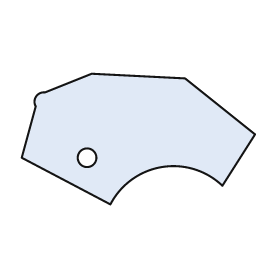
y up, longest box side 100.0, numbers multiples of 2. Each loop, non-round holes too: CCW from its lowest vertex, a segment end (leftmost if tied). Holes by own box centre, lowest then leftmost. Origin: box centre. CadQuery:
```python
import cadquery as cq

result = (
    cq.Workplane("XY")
    .moveTo(-12.0, -28.0)
    .threePointArc((10.0, -12.0), (36.0, -20.0))
    .lineTo(50.0, 2.0)
    .lineTo(20.0, 26.0)
    .lineTo(-20.0, 28.0)
    .lineTo(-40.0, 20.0)
    .threePointArc((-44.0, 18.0), (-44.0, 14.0))
    .lineTo(-50.0, -8.0)
    .close()
    .moveTo(-22.0, -8.0)
    .circle(4.0)
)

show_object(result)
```